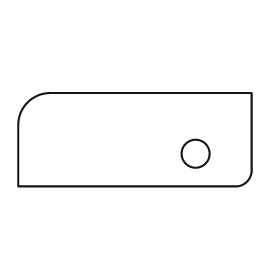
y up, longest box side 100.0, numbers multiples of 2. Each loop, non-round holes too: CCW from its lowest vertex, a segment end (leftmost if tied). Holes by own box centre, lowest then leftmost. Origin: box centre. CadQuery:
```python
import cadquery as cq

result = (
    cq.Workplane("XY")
    .moveTo(-50.0, -20.0)
    .lineTo(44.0, -20.0)
    .threePointArc((48.0, -18.0), (50.0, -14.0))
    .lineTo(50.0, 20.0)
    .lineTo(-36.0, 20.0)
    .threePointArc((-46.0, 16.0), (-50.0, 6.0))
    .close()
    .moveTo(26.0, -6.0)
    .circle(6.0)
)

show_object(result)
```